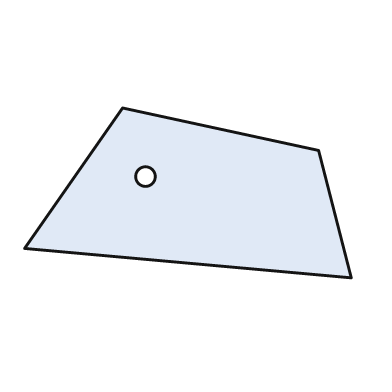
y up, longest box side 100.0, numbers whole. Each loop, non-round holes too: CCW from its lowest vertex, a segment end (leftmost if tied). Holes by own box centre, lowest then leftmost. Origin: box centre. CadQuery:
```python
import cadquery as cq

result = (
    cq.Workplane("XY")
    .moveTo(50.0, -26.0)
    .lineTo(40.0, 13.0)
    .lineTo(-20.0, 26.0)
    .lineTo(-50.0, -17.0)
    .close()
    .moveTo(-13.0, 5.0)
    .circle(3.0)
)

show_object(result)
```